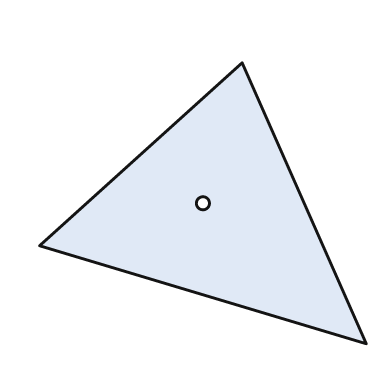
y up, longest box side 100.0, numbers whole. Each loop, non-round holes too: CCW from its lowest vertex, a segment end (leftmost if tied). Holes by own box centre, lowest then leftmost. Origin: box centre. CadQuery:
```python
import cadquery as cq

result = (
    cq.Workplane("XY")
    .moveTo(50.0, -43.0)
    .lineTo(12.0, 43.0)
    .lineTo(-50.0, -13.0)
    .close()
    .moveTo(0.0, 0.0)
    .circle(2.0)
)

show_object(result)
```